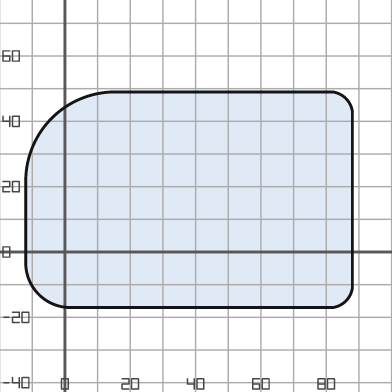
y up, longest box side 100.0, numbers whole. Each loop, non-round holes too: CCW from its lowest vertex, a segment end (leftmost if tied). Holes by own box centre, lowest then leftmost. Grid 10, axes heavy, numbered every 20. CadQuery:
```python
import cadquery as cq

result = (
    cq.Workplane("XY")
    .moveTo(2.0, -17.0)
    .lineTo(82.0, -17.0)
    .threePointArc((86.0, -15.0), (88.0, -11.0))
    .lineTo(88.0, 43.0)
    .threePointArc((86.0, 47.0), (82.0, 49.0))
    .lineTo(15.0, 49.0)
    .threePointArc((-4.0, 41.0), (-12.0, 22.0))
    .lineTo(-12.0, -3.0)
    .threePointArc((-8.0, -13.0), (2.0, -17.0))
    .close()
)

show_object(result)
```